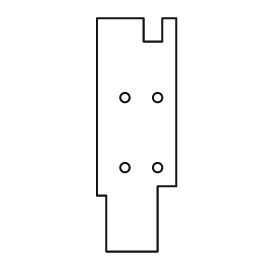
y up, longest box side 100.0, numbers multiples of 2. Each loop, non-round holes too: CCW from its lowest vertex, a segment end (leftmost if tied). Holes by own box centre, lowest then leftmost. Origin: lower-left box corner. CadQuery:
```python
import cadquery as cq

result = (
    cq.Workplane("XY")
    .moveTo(4.0, 0.0)
    .lineTo(26.0, 0.0)
    .lineTo(26.0, 28.0)
    .lineTo(34.0, 28.0)
    .lineTo(34.0, 100.0)
    .lineTo(28.0, 100.0)
    .lineTo(28.0, 90.0)
    .lineTo(20.0, 90.0)
    .lineTo(20.0, 100.0)
    .lineTo(0.0, 100.0)
    .lineTo(0.0, 24.0)
    .lineTo(4.0, 24.0)
    .close()
    .moveTo(12.0, 36.0)
    .circle(2.0)
    .moveTo(26.0, 36.0)
    .circle(2.0)
    .moveTo(12.0, 66.0)
    .circle(2.0)
    .moveTo(26.0, 66.0)
    .circle(2.0)
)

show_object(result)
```